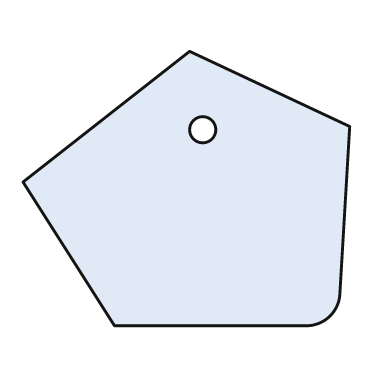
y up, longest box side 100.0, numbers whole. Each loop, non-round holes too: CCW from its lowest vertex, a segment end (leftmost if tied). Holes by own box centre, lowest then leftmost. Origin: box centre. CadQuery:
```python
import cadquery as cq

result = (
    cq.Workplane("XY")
    .moveTo(-22.0, -42.0)
    .lineTo(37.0, -42.0)
    .threePointArc((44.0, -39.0), (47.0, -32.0))
    .lineTo(50.0, 19.0)
    .lineTo(1.0, 42.0)
    .lineTo(-50.0, 2.0)
    .close()
    .moveTo(5.0, 18.0)
    .circle(4.0)
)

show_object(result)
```